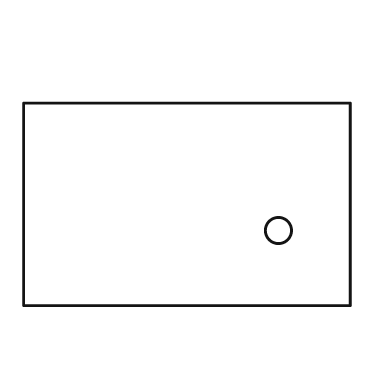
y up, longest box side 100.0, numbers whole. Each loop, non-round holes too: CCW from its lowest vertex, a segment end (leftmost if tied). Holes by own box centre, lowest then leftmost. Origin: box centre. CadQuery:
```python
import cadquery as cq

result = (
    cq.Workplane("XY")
    .moveTo(-50.0, -31.0)
    .lineTo(50.0, -31.0)
    .lineTo(50.0, 31.0)
    .lineTo(-50.0, 31.0)
    .close()
    .moveTo(28.0, -8.0)
    .circle(4.0)
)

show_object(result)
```